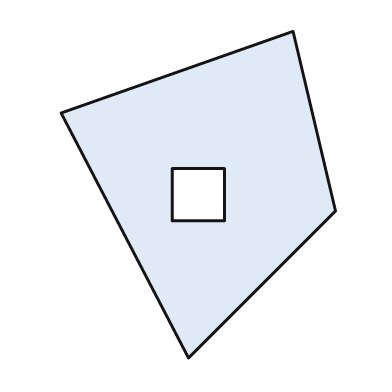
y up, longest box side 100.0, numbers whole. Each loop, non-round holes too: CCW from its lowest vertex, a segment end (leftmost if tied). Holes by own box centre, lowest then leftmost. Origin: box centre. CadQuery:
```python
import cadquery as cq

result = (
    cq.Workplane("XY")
    .moveTo(-3.0, -50.0)
    .lineTo(42.0, -5.0)
    .lineTo(29.0, 50.0)
    .lineTo(-42.0, 25.0)
    .close()
    .moveTo(-8.0, -8.0)
    .lineTo(8.0, -8.0)
    .lineTo(8.0, 8.0)
    .lineTo(-8.0, 8.0)
    .close()
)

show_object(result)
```